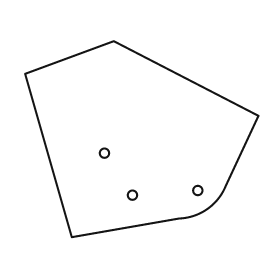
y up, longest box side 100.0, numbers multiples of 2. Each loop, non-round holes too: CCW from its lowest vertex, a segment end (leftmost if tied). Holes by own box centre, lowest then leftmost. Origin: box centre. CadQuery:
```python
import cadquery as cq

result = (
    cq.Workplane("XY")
    .moveTo(-30.0, -42.0)
    .lineTo(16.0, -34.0)
    .threePointArc((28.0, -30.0), (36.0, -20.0))
    .lineTo(50.0, 10.0)
    .lineTo(-12.0, 42.0)
    .lineTo(-50.0, 28.0)
    .close()
    .moveTo(-4.0, -24.0)
    .circle(2.0)
    .moveTo(24.0, -22.0)
    .circle(2.0)
    .moveTo(-16.0, -6.0)
    .circle(2.0)
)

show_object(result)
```